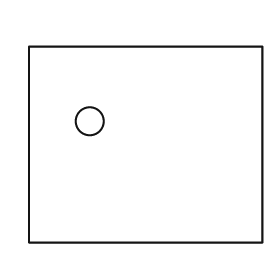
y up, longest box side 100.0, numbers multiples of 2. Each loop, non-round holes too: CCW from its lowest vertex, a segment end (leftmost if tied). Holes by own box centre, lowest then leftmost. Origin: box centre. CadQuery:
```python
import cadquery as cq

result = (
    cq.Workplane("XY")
    .moveTo(-50.0, -42.0)
    .lineTo(50.0, -42.0)
    .lineTo(50.0, 42.0)
    .lineTo(-50.0, 42.0)
    .close()
    .moveTo(-24.0, 10.0)
    .circle(6.0)
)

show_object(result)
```